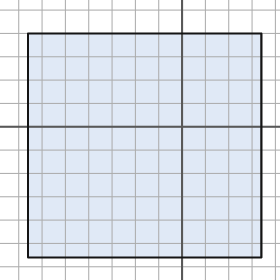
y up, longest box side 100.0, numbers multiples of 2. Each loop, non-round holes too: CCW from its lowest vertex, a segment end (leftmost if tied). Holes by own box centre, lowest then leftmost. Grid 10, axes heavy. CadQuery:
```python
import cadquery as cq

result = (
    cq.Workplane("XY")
    .moveTo(-66.0, -56.0)
    .lineTo(34.0, -56.0)
    .lineTo(34.0, 40.0)
    .lineTo(-66.0, 40.0)
    .close()
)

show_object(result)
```